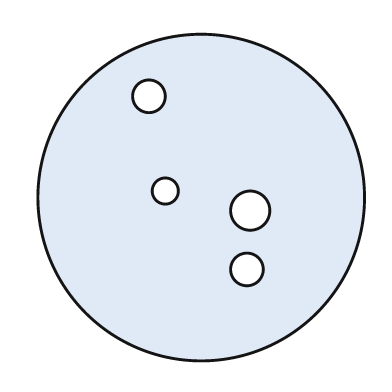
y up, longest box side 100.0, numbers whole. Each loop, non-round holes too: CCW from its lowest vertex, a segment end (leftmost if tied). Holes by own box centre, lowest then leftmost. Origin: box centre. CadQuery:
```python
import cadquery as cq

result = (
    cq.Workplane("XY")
    .moveTo(0.0, 0.0)
    .circle(50.0)
    .moveTo(14.0, -22.0)
    .circle(5.0)
    .moveTo(15.0, -4.0)
    .circle(6.0)
    .moveTo(-11.0, 2.0)
    .circle(4.0)
    .moveTo(-16.0, 31.0)
    .circle(5.0)
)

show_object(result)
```